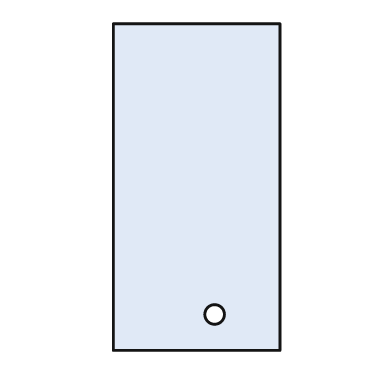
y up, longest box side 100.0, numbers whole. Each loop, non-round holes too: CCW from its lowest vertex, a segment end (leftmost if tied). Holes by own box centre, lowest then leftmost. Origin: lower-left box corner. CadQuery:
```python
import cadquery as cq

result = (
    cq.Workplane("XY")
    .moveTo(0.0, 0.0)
    .lineTo(51.0, 0.0)
    .lineTo(51.0, 100.0)
    .lineTo(0.0, 100.0)
    .close()
    .moveTo(31.0, 11.0)
    .circle(3.0)
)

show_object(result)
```